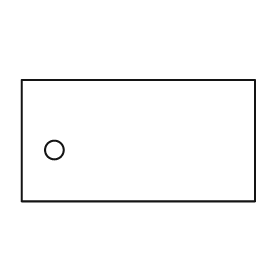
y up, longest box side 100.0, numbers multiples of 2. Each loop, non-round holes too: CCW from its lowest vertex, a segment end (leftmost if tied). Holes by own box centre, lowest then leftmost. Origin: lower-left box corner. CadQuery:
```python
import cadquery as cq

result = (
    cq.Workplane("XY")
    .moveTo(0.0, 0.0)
    .lineTo(100.0, 0.0)
    .lineTo(100.0, 52.0)
    .lineTo(0.0, 52.0)
    .close()
    .moveTo(14.0, 22.0)
    .circle(4.0)
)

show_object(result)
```